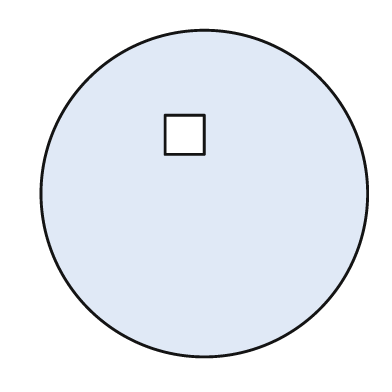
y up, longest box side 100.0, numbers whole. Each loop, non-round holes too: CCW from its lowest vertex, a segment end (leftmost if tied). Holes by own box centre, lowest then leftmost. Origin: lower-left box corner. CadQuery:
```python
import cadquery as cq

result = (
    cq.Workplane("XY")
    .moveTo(50.0, 50.0)
    .circle(50.0)
    .moveTo(38.0, 62.0)
    .lineTo(50.0, 62.0)
    .lineTo(50.0, 74.0)
    .lineTo(38.0, 74.0)
    .close()
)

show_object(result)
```